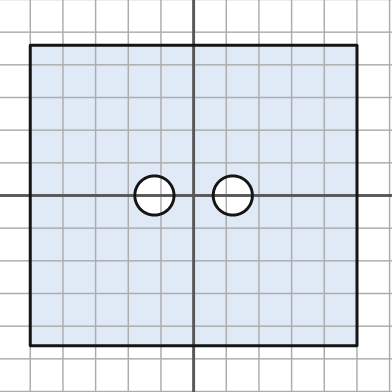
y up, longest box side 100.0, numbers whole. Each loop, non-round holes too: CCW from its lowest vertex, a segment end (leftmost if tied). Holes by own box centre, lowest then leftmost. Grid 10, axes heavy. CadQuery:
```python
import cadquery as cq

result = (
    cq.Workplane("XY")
    .moveTo(-50.0, -46.0)
    .lineTo(50.0, -46.0)
    .lineTo(50.0, 46.0)
    .lineTo(-50.0, 46.0)
    .close()
    .moveTo(-12.0, 0.0)
    .circle(6.0)
    .moveTo(12.0, 0.0)
    .circle(6.0)
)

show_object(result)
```